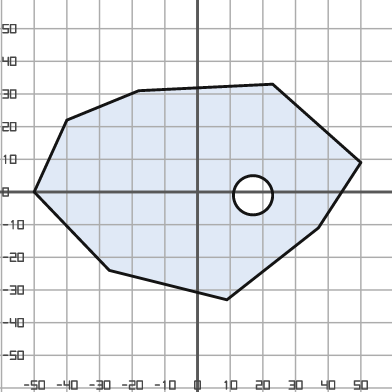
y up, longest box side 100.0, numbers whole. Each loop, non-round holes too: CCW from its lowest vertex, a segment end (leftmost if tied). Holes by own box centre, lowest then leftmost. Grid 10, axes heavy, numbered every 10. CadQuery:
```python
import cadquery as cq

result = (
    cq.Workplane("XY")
    .moveTo(9.0, -33.0)
    .lineTo(37.0, -11.0)
    .lineTo(50.0, 9.0)
    .lineTo(23.0, 33.0)
    .lineTo(-18.0, 31.0)
    .lineTo(-40.0, 22.0)
    .lineTo(-50.0, 0.0)
    .lineTo(-27.0, -24.0)
    .close()
    .moveTo(17.0, -1.0)
    .circle(6.0)
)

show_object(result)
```